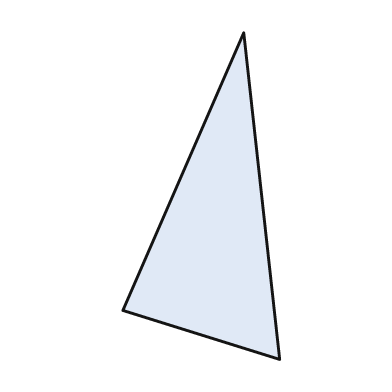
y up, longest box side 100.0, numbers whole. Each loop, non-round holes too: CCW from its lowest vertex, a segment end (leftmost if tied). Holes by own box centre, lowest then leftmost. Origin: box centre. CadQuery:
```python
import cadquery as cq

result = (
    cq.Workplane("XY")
    .moveTo(24.0, -50.0)
    .lineTo(13.0, 50.0)
    .lineTo(-24.0, -35.0)
    .close()
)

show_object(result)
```